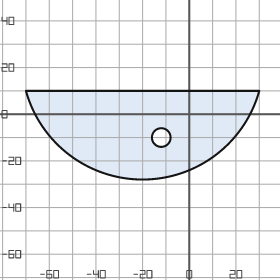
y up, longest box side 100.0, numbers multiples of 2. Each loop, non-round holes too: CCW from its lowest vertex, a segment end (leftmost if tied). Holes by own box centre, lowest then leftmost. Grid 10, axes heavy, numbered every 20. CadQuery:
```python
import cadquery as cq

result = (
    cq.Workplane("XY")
    .moveTo(-70.0, 10.0)
    .threePointArc((-20.0, -28.0), (30.0, 10.0))
    .close()
    .moveTo(-12.0, -10.0)
    .circle(4.0)
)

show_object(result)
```